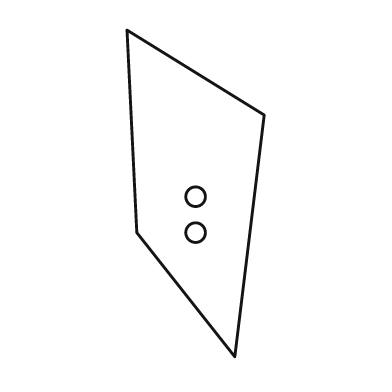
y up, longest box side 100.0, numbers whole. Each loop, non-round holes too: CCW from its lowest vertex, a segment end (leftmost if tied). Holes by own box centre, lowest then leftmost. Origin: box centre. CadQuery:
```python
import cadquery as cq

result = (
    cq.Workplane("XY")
    .moveTo(12.0, -50.0)
    .lineTo(21.0, 24.0)
    .lineTo(-21.0, 50.0)
    .lineTo(-18.0, -12.0)
    .close()
    .moveTo(0.0, -12.0)
    .circle(3.0)
    .moveTo(0.0, -1.0)
    .circle(3.0)
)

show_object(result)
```